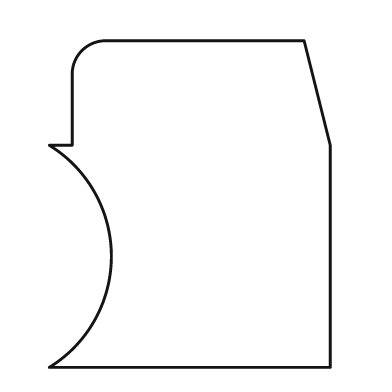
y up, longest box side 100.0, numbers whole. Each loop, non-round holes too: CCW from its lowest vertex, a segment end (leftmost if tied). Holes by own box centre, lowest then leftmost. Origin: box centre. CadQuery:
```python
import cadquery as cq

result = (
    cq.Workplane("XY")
    .moveTo(-43.0, -50.0)
    .lineTo(43.0, -50.0)
    .lineTo(43.0, 18.0)
    .lineTo(35.0, 50.0)
    .lineTo(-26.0, 50.0)
    .threePointArc((-33.0, 47.0), (-36.0, 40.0))
    .lineTo(-36.0, 18.0)
    .lineTo(-43.0, 18.0)
    .threePointArc((-24.0, -16.0), (-43.0, -50.0))
    .close()
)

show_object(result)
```